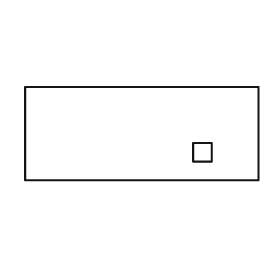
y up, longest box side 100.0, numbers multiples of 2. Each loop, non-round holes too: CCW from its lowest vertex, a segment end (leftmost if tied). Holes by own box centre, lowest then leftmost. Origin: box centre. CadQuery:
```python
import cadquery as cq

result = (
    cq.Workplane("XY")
    .moveTo(-50.0, -20.0)
    .lineTo(50.0, -20.0)
    .lineTo(50.0, 20.0)
    .lineTo(-50.0, 20.0)
    .close()
    .moveTo(22.0, -12.0)
    .lineTo(30.0, -12.0)
    .lineTo(30.0, -4.0)
    .lineTo(22.0, -4.0)
    .close()
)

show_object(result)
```